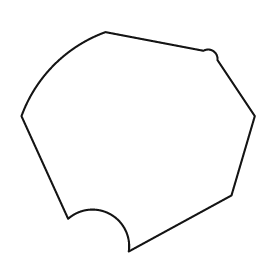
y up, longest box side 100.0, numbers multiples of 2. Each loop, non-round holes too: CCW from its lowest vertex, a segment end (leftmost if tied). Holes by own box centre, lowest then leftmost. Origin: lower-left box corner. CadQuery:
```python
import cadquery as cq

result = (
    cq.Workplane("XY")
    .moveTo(46.0, 0.0)
    .lineTo(90.0, 24.0)
    .lineTo(100.0, 58.0)
    .lineTo(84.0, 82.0)
    .threePointArc((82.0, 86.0), (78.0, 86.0))
    .lineTo(36.0, 94.0)
    .threePointArc((14.0, 80.0), (0.0, 58.0))
    .lineTo(20.0, 14.0)
    .threePointArc((38.0, 16.0), (46.0, 0.0))
    .close()
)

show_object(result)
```